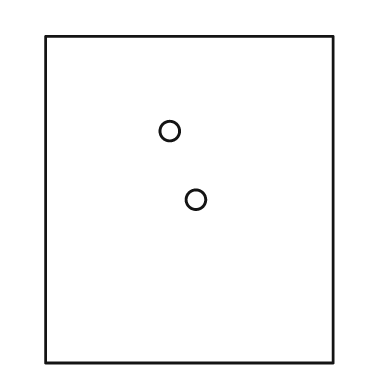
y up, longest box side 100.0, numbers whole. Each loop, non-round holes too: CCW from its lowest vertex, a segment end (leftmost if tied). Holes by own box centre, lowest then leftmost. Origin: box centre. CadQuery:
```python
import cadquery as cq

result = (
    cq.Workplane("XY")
    .moveTo(-44.0, -50.0)
    .lineTo(44.0, -50.0)
    .lineTo(44.0, 50.0)
    .lineTo(-44.0, 50.0)
    .close()
    .moveTo(2.0, 0.0)
    .circle(3.0)
    .moveTo(-6.0, 21.0)
    .circle(3.0)
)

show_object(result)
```